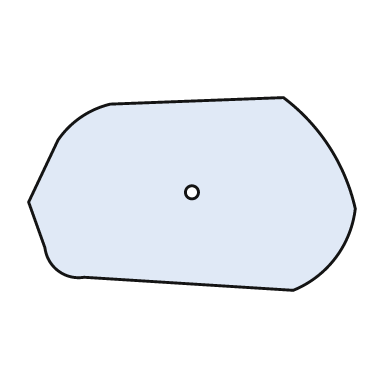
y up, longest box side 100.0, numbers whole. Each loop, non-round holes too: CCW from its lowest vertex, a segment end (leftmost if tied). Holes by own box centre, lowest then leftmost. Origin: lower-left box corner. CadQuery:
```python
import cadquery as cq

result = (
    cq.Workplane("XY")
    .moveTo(81.0, 0.0)
    .threePointArc((94.0, 10.0), (100.0, 25.0))
    .threePointArc((92.0, 44.0), (78.0, 59.0))
    .lineTo(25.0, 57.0)
    .threePointArc((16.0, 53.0), (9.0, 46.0))
    .lineTo(0.0, 27.0)
    .lineTo(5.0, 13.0)
    .threePointArc((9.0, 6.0), (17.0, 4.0))
    .close()
    .moveTo(50.0, 30.0)
    .circle(2.0)
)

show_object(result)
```